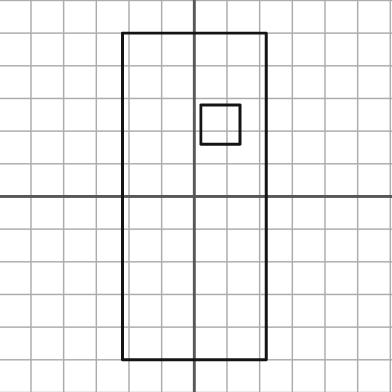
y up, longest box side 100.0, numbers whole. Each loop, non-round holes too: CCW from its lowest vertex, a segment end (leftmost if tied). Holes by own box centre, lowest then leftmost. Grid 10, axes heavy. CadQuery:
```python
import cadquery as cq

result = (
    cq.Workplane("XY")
    .moveTo(-22.0, -50.0)
    .lineTo(22.0, -50.0)
    .lineTo(22.0, 50.0)
    .lineTo(-22.0, 50.0)
    .close()
    .moveTo(2.0, 16.0)
    .lineTo(14.0, 16.0)
    .lineTo(14.0, 28.0)
    .lineTo(2.0, 28.0)
    .close()
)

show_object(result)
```